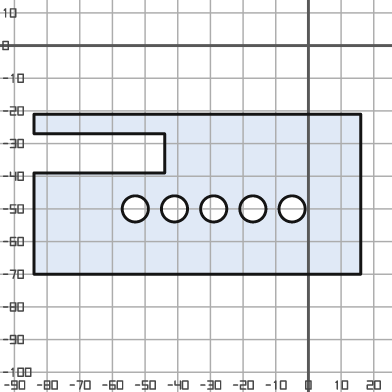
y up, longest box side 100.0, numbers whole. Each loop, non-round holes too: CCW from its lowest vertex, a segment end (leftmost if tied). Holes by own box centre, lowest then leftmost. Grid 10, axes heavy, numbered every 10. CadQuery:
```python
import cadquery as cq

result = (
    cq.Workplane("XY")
    .moveTo(-84.0, -70.0)
    .lineTo(16.0, -70.0)
    .lineTo(16.0, -21.0)
    .lineTo(-84.0, -21.0)
    .lineTo(-84.0, -27.0)
    .lineTo(-44.0, -27.0)
    .lineTo(-44.0, -39.0)
    .lineTo(-84.0, -39.0)
    .close()
    .moveTo(-53.0, -50.0)
    .circle(4.0)
    .moveTo(-41.0, -50.0)
    .circle(4.0)
    .moveTo(-29.0, -50.0)
    .circle(4.0)
    .moveTo(-17.0, -50.0)
    .circle(4.0)
    .moveTo(-5.0, -50.0)
    .circle(4.0)
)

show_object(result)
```